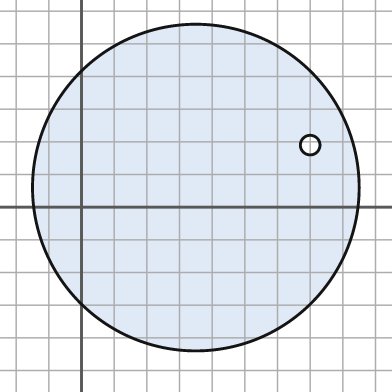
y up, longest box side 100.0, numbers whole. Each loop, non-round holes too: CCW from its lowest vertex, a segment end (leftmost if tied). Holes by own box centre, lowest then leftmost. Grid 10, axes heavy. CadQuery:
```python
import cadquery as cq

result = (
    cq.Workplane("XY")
    .moveTo(35.0, 6.0)
    .circle(50.0)
    .moveTo(70.0, 19.0)
    .circle(3.0)
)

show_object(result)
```